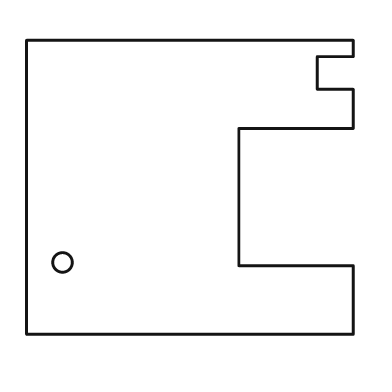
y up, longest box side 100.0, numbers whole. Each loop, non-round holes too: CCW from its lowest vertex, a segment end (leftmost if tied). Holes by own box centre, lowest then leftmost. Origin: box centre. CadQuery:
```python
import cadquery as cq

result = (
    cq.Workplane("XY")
    .moveTo(-50.0, -45.0)
    .lineTo(50.0, -45.0)
    .lineTo(50.0, -24.0)
    .lineTo(15.0, -24.0)
    .lineTo(15.0, 18.0)
    .lineTo(50.0, 18.0)
    .lineTo(50.0, 30.0)
    .lineTo(39.0, 30.0)
    .lineTo(39.0, 40.0)
    .lineTo(50.0, 40.0)
    .lineTo(50.0, 45.0)
    .lineTo(-50.0, 45.0)
    .close()
    .moveTo(-39.0, -23.0)
    .circle(3.0)
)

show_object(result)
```